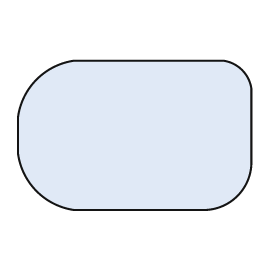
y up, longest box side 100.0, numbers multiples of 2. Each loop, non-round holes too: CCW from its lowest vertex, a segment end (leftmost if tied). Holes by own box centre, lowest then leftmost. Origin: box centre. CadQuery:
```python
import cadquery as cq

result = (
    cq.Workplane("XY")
    .moveTo(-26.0, -32.0)
    .lineTo(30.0, -32.0)
    .threePointArc((44.0, -26.0), (50.0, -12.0))
    .lineTo(50.0, 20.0)
    .threePointArc((46.0, 28.0), (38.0, 32.0))
    .lineTo(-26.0, 32.0)
    .threePointArc((-42.0, 24.0), (-50.0, 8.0))
    .lineTo(-50.0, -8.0)
    .threePointArc((-42.0, -24.0), (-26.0, -32.0))
    .close()
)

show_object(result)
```